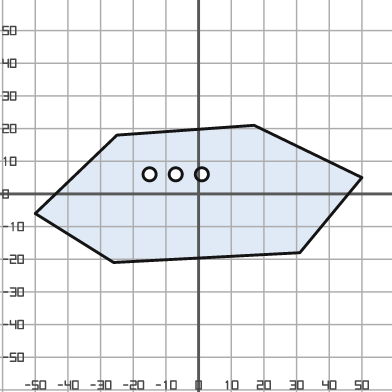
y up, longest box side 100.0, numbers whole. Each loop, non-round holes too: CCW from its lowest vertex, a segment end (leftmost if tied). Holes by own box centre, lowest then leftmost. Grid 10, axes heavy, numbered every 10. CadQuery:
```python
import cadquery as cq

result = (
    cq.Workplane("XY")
    .moveTo(-26.0, -21.0)
    .lineTo(31.0, -18.0)
    .lineTo(50.0, 5.0)
    .lineTo(17.0, 21.0)
    .lineTo(-25.0, 18.0)
    .lineTo(-50.0, -6.0)
    .close()
    .moveTo(-15.0, 6.0)
    .circle(2.0)
    .moveTo(-7.0, 6.0)
    .circle(2.0)
    .moveTo(1.0, 6.0)
    .circle(2.0)
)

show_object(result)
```